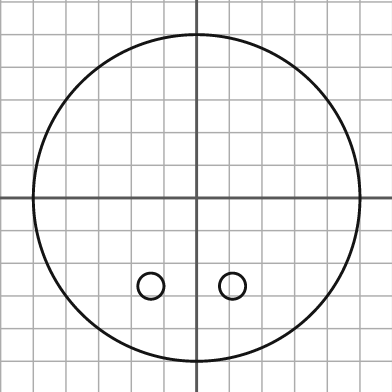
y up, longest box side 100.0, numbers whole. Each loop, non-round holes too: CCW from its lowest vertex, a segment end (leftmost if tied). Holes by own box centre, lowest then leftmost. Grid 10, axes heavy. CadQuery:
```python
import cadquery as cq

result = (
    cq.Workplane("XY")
    .moveTo(0.0, 0.0)
    .circle(50.0)
    .moveTo(-14.0, -27.0)
    .circle(4.0)
    .moveTo(11.0, -27.0)
    .circle(4.0)
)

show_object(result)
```